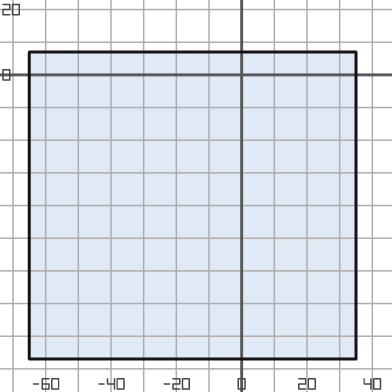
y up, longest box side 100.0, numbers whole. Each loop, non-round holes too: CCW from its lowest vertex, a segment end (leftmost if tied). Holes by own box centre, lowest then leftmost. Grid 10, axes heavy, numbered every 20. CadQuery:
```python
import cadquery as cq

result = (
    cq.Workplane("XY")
    .moveTo(-65.0, -87.0)
    .lineTo(35.0, -87.0)
    .lineTo(35.0, 7.0)
    .lineTo(-65.0, 7.0)
    .close()
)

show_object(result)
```